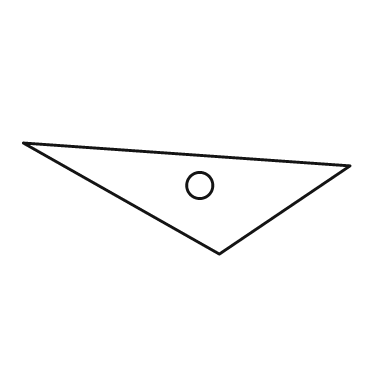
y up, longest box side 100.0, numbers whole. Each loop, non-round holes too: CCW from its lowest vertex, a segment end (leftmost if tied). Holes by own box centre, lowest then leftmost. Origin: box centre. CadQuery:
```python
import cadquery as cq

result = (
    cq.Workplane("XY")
    .moveTo(10.0, -17.0)
    .lineTo(50.0, 10.0)
    .lineTo(-50.0, 17.0)
    .close()
    .moveTo(4.0, 4.0)
    .circle(4.0)
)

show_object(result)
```